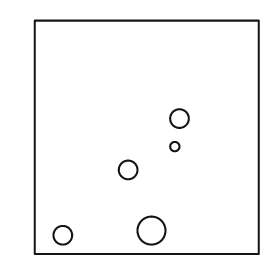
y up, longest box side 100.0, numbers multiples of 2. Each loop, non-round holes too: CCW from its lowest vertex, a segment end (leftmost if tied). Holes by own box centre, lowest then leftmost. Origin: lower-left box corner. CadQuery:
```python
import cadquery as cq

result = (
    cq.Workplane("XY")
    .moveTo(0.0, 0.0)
    .lineTo(96.0, 0.0)
    .lineTo(96.0, 100.0)
    .lineTo(0.0, 100.0)
    .close()
    .moveTo(12.0, 8.0)
    .circle(4.0)
    .moveTo(50.0, 10.0)
    .circle(6.0)
    .moveTo(40.0, 36.0)
    .circle(4.0)
    .moveTo(60.0, 46.0)
    .circle(2.0)
    .moveTo(62.0, 58.0)
    .circle(4.0)
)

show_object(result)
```